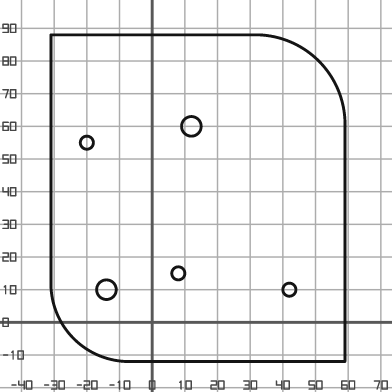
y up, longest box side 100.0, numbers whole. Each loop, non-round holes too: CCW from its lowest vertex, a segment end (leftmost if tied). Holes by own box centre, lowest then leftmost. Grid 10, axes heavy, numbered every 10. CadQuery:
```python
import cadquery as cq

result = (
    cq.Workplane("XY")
    .moveTo(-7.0, -12.0)
    .lineTo(59.0, -12.0)
    .lineTo(59.0, 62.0)
    .threePointArc((51.0, 80.0), (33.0, 88.0))
    .lineTo(-31.0, 88.0)
    .lineTo(-31.0, 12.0)
    .threePointArc((-24.0, -5.0), (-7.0, -12.0))
    .close()
    .moveTo(-14.0, 10.0)
    .circle(3.0)
    .moveTo(42.0, 10.0)
    .circle(2.0)
    .moveTo(8.0, 15.0)
    .circle(2.0)
    .moveTo(-20.0, 55.0)
    .circle(2.0)
    .moveTo(12.0, 60.0)
    .circle(3.0)
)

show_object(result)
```